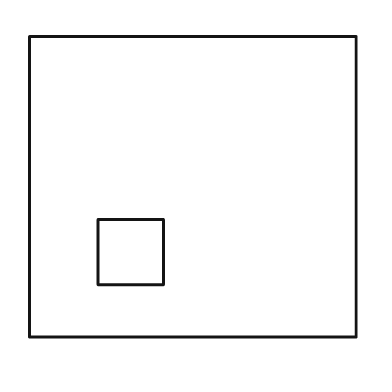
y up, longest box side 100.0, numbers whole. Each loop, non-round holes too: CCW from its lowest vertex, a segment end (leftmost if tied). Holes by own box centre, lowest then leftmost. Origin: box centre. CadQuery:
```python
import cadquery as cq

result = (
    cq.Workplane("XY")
    .moveTo(-50.0, -46.0)
    .lineTo(50.0, -46.0)
    .lineTo(50.0, 46.0)
    .lineTo(-50.0, 46.0)
    .close()
    .moveTo(-29.0, -30.0)
    .lineTo(-9.0, -30.0)
    .lineTo(-9.0, -10.0)
    .lineTo(-29.0, -10.0)
    .close()
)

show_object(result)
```